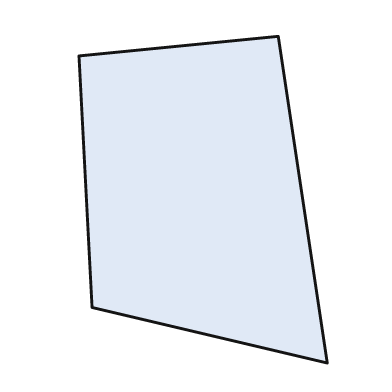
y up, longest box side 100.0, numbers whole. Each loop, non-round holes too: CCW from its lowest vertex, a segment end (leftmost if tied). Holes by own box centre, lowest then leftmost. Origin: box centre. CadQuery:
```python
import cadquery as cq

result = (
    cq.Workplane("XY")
    .moveTo(38.0, -50.0)
    .lineTo(23.0, 50.0)
    .lineTo(-38.0, 44.0)
    .lineTo(-34.0, -33.0)
    .close()
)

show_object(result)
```